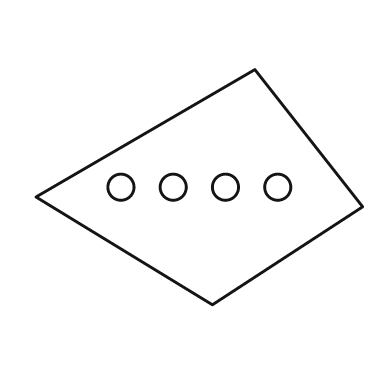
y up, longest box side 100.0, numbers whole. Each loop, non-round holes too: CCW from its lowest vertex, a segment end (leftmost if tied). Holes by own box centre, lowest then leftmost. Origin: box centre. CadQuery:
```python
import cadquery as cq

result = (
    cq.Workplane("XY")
    .moveTo(4.0, -36.0)
    .lineTo(50.0, -6.0)
    .lineTo(17.0, 36.0)
    .lineTo(-50.0, -3.0)
    .close()
    .moveTo(-24.0, 0.0)
    .circle(4.0)
    .moveTo(-8.0, 0.0)
    .circle(4.0)
    .moveTo(8.0, 0.0)
    .circle(4.0)
    .moveTo(24.0, 0.0)
    .circle(4.0)
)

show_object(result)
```